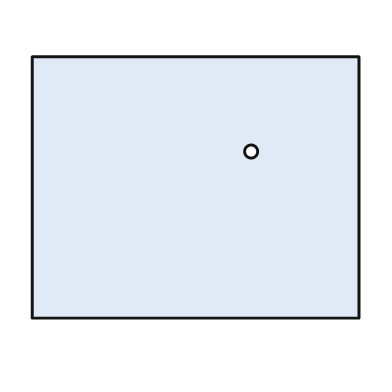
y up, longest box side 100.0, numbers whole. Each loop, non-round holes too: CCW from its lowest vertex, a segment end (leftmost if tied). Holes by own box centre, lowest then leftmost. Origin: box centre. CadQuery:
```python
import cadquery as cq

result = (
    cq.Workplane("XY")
    .moveTo(-50.0, -40.0)
    .lineTo(50.0, -40.0)
    .lineTo(50.0, 40.0)
    .lineTo(-50.0, 40.0)
    .close()
    .moveTo(17.0, 11.0)
    .circle(2.0)
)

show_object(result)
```